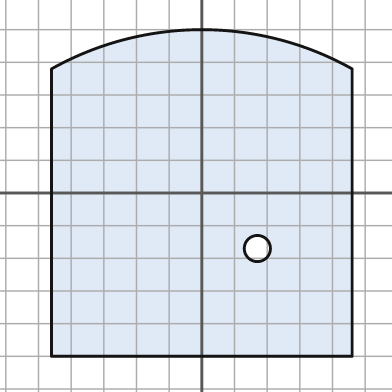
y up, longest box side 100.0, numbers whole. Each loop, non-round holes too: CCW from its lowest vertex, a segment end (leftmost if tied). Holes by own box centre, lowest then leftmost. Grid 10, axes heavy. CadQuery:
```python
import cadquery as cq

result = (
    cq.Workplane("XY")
    .moveTo(-46.0, -50.0)
    .lineTo(46.0, -50.0)
    .lineTo(46.0, 38.0)
    .threePointArc((0.0, 50.0), (-46.0, 38.0))
    .close()
    .moveTo(17.0, -17.0)
    .circle(4.0)
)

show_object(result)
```